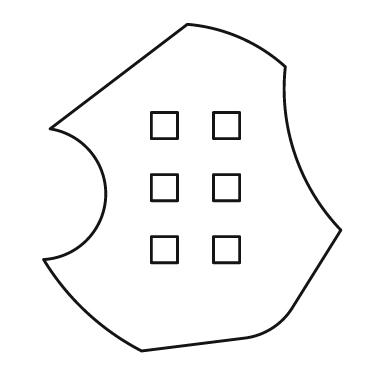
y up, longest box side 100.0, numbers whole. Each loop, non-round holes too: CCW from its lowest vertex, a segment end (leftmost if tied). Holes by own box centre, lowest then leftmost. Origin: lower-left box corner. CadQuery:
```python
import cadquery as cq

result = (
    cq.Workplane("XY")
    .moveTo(30.0, 0.0)
    .lineTo(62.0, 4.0)
    .threePointArc((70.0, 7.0), (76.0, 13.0))
    .lineTo(91.0, 37.0)
    .threePointArc((77.0, 60.0), (74.0, 87.0))
    .threePointArc((60.0, 96.0), (44.0, 100.0))
    .lineTo(2.0, 68.0)
    .threePointArc((19.0, 47.0), (0.0, 28.0))
    .threePointArc((13.0, 12.0), (30.0, 0.0))
    .close()
    .moveTo(33.0, 27.0)
    .lineTo(41.0, 27.0)
    .lineTo(41.0, 35.0)
    .lineTo(33.0, 35.0)
    .close()
    .moveTo(52.0, 27.0)
    .lineTo(60.0, 27.0)
    .lineTo(60.0, 35.0)
    .lineTo(52.0, 35.0)
    .close()
    .moveTo(33.0, 46.0)
    .lineTo(41.0, 46.0)
    .lineTo(41.0, 54.0)
    .lineTo(33.0, 54.0)
    .close()
    .moveTo(52.0, 46.0)
    .lineTo(60.0, 46.0)
    .lineTo(60.0, 54.0)
    .lineTo(52.0, 54.0)
    .close()
    .moveTo(33.0, 65.0)
    .lineTo(41.0, 65.0)
    .lineTo(41.0, 73.0)
    .lineTo(33.0, 73.0)
    .close()
    .moveTo(52.0, 65.0)
    .lineTo(60.0, 65.0)
    .lineTo(60.0, 73.0)
    .lineTo(52.0, 73.0)
    .close()
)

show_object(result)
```